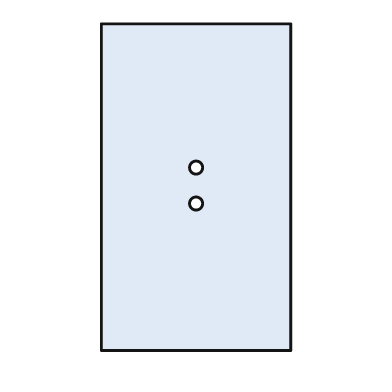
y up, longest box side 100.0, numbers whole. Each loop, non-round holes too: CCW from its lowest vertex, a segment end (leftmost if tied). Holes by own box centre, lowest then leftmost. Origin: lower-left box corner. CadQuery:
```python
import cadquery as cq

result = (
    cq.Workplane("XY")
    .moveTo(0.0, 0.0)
    .lineTo(58.0, 0.0)
    .lineTo(58.0, 100.0)
    .lineTo(0.0, 100.0)
    .close()
    .moveTo(29.0, 45.0)
    .circle(2.0)
    .moveTo(29.0, 56.0)
    .circle(2.0)
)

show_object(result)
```